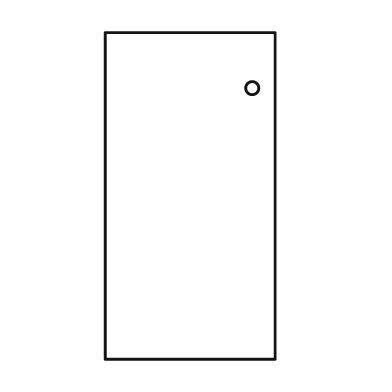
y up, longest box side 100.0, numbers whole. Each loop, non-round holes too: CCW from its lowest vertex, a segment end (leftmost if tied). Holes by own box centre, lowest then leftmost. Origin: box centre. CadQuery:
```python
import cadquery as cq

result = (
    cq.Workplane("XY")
    .moveTo(-26.0, -50.0)
    .lineTo(26.0, -50.0)
    .lineTo(26.0, 50.0)
    .lineTo(-26.0, 50.0)
    .close()
    .moveTo(19.0, 33.0)
    .circle(2.0)
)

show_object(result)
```